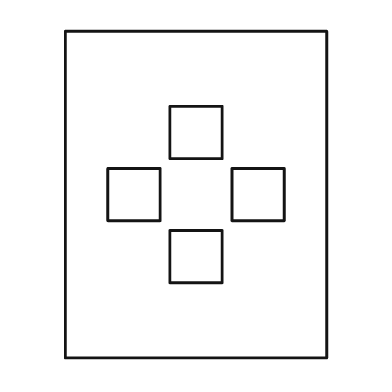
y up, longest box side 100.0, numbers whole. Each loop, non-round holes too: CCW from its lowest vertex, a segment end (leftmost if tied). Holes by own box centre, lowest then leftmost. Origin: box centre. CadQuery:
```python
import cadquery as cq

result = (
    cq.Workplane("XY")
    .moveTo(-40.0, -50.0)
    .lineTo(40.0, -50.0)
    .lineTo(40.0, 50.0)
    .lineTo(-40.0, 50.0)
    .close()
    .moveTo(-8.0, -27.0)
    .lineTo(8.0, -27.0)
    .lineTo(8.0, -11.0)
    .lineTo(-8.0, -11.0)
    .close()
    .moveTo(-27.0, -8.0)
    .lineTo(-11.0, -8.0)
    .lineTo(-11.0, 8.0)
    .lineTo(-27.0, 8.0)
    .close()
    .moveTo(11.0, -8.0)
    .lineTo(27.0, -8.0)
    .lineTo(27.0, 8.0)
    .lineTo(11.0, 8.0)
    .close()
    .moveTo(-8.0, 11.0)
    .lineTo(8.0, 11.0)
    .lineTo(8.0, 27.0)
    .lineTo(-8.0, 27.0)
    .close()
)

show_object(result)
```